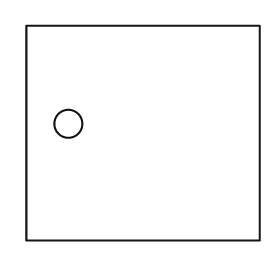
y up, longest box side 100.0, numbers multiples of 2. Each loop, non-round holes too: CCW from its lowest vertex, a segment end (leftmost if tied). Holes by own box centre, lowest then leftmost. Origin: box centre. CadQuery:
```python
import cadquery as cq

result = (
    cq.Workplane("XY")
    .moveTo(-50.0, -46.0)
    .lineTo(50.0, -46.0)
    .lineTo(50.0, 46.0)
    .lineTo(-50.0, 46.0)
    .close()
    .moveTo(-32.0, 4.0)
    .circle(6.0)
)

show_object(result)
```